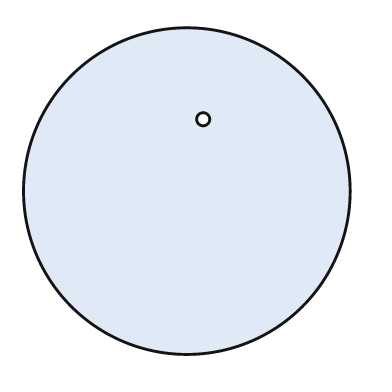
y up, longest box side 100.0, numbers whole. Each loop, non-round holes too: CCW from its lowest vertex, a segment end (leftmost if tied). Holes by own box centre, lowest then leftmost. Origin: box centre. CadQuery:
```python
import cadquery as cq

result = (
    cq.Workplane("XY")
    .moveTo(0.0, 0.0)
    .circle(50.0)
    .moveTo(5.0, 22.0)
    .circle(2.0)
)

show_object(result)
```